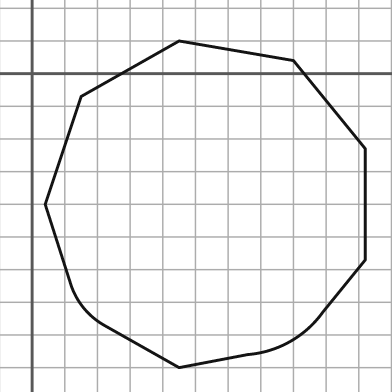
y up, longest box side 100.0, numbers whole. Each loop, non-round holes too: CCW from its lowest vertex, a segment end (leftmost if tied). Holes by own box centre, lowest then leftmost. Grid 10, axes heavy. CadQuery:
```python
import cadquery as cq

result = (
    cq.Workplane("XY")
    .moveTo(45.0, -90.0)
    .lineTo(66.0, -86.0)
    .threePointArc((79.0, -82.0), (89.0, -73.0))
    .lineTo(102.0, -57.0)
    .lineTo(102.0, -23.0)
    .lineTo(80.0, 4.0)
    .lineTo(45.0, 10.0)
    .lineTo(15.0, -7.0)
    .lineTo(4.0, -40.0)
    .lineTo(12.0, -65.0)
    .threePointArc((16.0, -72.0), (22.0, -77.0))
    .close()
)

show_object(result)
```